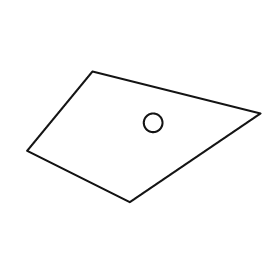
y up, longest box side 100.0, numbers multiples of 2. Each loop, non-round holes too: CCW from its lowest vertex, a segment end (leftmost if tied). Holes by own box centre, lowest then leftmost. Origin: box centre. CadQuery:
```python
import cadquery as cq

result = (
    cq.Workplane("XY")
    .moveTo(-6.0, -28.0)
    .lineTo(50.0, 10.0)
    .lineTo(-22.0, 28.0)
    .lineTo(-50.0, -6.0)
    .close()
    .moveTo(4.0, 6.0)
    .circle(4.0)
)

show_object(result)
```